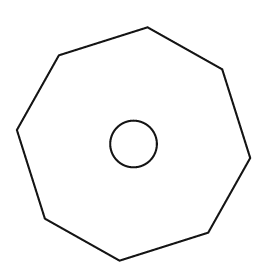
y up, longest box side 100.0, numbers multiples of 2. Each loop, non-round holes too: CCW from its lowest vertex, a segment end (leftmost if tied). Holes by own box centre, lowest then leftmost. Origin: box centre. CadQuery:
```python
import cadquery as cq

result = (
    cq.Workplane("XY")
    .moveTo(-6.0, -50.0)
    .lineTo(32.0, -38.0)
    .lineTo(50.0, -6.0)
    .lineTo(38.0, 32.0)
    .lineTo(6.0, 50.0)
    .lineTo(-32.0, 38.0)
    .lineTo(-50.0, 6.0)
    .lineTo(-38.0, -32.0)
    .close()
    .moveTo(0.0, 0.0)
    .circle(10.0)
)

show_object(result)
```